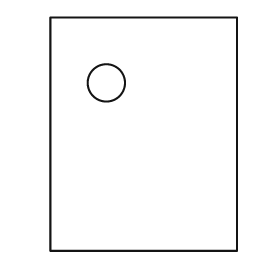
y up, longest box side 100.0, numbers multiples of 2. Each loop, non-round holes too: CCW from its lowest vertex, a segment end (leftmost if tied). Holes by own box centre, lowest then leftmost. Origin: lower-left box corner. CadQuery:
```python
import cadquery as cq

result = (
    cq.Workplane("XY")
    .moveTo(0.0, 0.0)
    .lineTo(80.0, 0.0)
    .lineTo(80.0, 100.0)
    .lineTo(0.0, 100.0)
    .close()
    .moveTo(24.0, 72.0)
    .circle(8.0)
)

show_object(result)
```